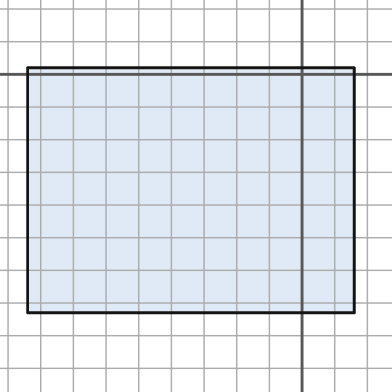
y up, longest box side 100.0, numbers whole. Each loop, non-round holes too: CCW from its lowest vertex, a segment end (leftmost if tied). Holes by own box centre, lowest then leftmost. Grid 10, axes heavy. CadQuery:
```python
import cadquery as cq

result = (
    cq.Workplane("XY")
    .moveTo(-84.0, -73.0)
    .lineTo(16.0, -73.0)
    .lineTo(16.0, 2.0)
    .lineTo(-84.0, 2.0)
    .close()
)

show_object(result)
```